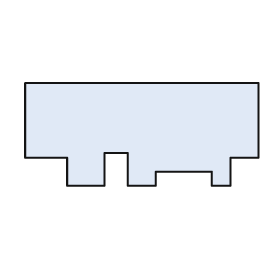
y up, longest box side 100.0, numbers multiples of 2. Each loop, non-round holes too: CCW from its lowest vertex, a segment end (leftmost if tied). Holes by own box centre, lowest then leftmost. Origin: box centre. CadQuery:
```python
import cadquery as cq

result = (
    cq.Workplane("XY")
    .moveTo(-32.0, -22.0)
    .lineTo(-16.0, -22.0)
    .lineTo(-16.0, -8.0)
    .lineTo(-6.0, -8.0)
    .lineTo(-6.0, -22.0)
    .lineTo(6.0, -22.0)
    .lineTo(6.0, -16.0)
    .lineTo(30.0, -16.0)
    .lineTo(30.0, -22.0)
    .lineTo(38.0, -22.0)
    .lineTo(38.0, -10.0)
    .lineTo(50.0, -10.0)
    .lineTo(50.0, 22.0)
    .lineTo(-50.0, 22.0)
    .lineTo(-50.0, -10.0)
    .lineTo(-32.0, -10.0)
    .close()
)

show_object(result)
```